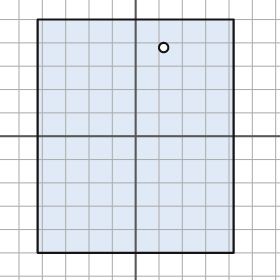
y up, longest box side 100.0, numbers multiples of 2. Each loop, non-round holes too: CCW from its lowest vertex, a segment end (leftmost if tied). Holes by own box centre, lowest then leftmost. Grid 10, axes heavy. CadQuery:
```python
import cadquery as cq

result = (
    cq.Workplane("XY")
    .moveTo(-42.0, -50.0)
    .lineTo(42.0, -50.0)
    .lineTo(42.0, 50.0)
    .lineTo(-42.0, 50.0)
    .close()
    .moveTo(12.0, 38.0)
    .circle(2.0)
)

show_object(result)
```